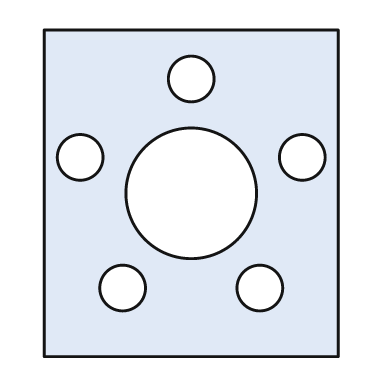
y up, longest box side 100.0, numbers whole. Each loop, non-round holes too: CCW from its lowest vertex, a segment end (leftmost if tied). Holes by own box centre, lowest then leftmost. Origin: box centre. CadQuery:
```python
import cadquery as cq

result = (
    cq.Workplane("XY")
    .moveTo(-45.0, -50.0)
    .lineTo(45.0, -50.0)
    .lineTo(45.0, 50.0)
    .lineTo(-45.0, 50.0)
    .close()
    .moveTo(-21.0, -29.0)
    .circle(7.0)
    .moveTo(21.0, -29.0)
    .circle(7.0)
    .moveTo(0.0, 0.0)
    .circle(20.0)
    .moveTo(-34.0, 11.0)
    .circle(7.0)
    .moveTo(34.0, 11.0)
    .circle(7.0)
    .moveTo(0.0, 35.0)
    .circle(7.0)
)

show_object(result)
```